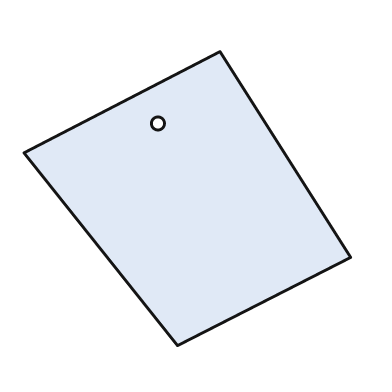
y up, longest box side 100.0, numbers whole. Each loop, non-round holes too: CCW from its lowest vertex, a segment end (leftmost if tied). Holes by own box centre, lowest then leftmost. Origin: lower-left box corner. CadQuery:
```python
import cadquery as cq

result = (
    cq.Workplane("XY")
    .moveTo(47.0, 0.0)
    .lineTo(100.0, 27.0)
    .lineTo(60.0, 90.0)
    .lineTo(0.0, 59.0)
    .close()
    .moveTo(41.0, 68.0)
    .circle(2.0)
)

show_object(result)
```